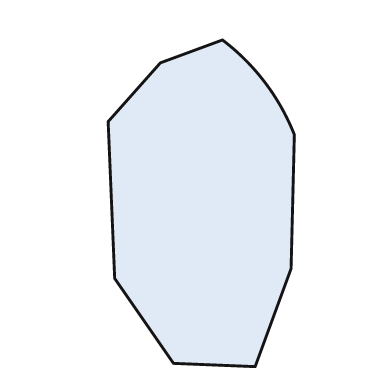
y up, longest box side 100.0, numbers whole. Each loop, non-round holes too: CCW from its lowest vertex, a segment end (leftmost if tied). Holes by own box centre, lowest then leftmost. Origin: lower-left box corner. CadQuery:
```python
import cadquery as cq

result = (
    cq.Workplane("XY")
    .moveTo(45.0, 0.0)
    .lineTo(56.0, 30.0)
    .lineTo(57.0, 71.0)
    .threePointArc((48.0, 87.0), (35.0, 100.0))
    .lineTo(16.0, 93.0)
    .lineTo(0.0, 75.0)
    .lineTo(2.0, 27.0)
    .lineTo(20.0, 1.0)
    .close()
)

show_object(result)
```